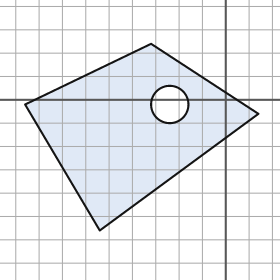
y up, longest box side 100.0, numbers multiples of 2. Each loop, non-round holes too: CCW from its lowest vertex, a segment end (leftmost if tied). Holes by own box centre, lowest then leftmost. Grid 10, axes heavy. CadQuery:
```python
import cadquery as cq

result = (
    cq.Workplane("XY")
    .moveTo(-54.0, -56.0)
    .lineTo(14.0, -6.0)
    .lineTo(-32.0, 24.0)
    .lineTo(-86.0, -2.0)
    .close()
    .moveTo(-24.0, -2.0)
    .circle(8.0)
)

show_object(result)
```